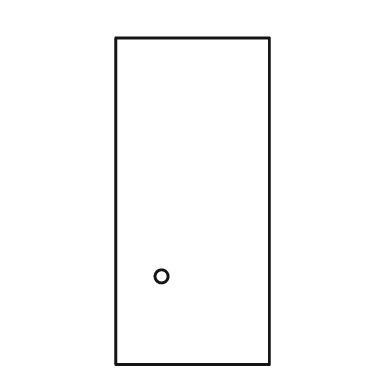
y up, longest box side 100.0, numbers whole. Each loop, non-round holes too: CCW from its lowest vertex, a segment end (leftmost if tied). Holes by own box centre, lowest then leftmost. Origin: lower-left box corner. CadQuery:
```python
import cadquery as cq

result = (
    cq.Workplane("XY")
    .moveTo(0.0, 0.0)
    .lineTo(47.0, 0.0)
    .lineTo(47.0, 100.0)
    .lineTo(0.0, 100.0)
    .close()
    .moveTo(14.0, 27.0)
    .circle(2.0)
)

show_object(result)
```